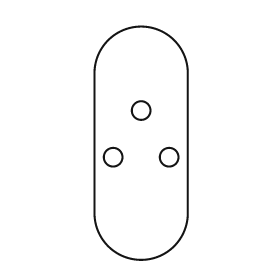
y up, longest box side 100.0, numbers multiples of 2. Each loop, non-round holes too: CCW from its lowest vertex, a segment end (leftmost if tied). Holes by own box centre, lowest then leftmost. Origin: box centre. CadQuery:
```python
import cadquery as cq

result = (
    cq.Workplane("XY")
    .moveTo(-20.0, -30.0)
    .threePointArc((0.0, -50.0), (20.0, -30.0))
    .lineTo(20.0, 30.0)
    .threePointArc((0.0, 50.0), (-20.0, 30.0))
    .close()
    .moveTo(-12.0, -6.0)
    .circle(4.0)
    .moveTo(12.0, -6.0)
    .circle(4.0)
    .moveTo(0.0, 14.0)
    .circle(4.0)
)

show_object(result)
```